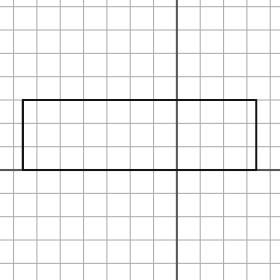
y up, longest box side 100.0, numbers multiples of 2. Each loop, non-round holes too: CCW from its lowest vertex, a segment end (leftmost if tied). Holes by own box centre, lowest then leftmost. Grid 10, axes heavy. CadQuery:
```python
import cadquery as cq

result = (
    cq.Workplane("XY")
    .moveTo(-66.0, 0.0)
    .lineTo(34.0, 0.0)
    .lineTo(34.0, 30.0)
    .lineTo(-66.0, 30.0)
    .close()
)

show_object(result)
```